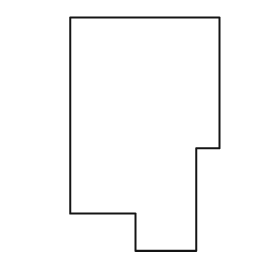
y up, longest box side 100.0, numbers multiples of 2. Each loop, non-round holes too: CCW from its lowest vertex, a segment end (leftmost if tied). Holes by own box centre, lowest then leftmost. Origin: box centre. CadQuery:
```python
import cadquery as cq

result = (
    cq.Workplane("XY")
    .moveTo(-4.0, -50.0)
    .lineTo(22.0, -50.0)
    .lineTo(22.0, -6.0)
    .lineTo(32.0, -6.0)
    .lineTo(32.0, 50.0)
    .lineTo(-32.0, 50.0)
    .lineTo(-32.0, -34.0)
    .lineTo(-4.0, -34.0)
    .close()
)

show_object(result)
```